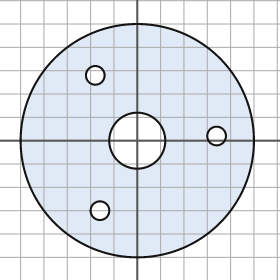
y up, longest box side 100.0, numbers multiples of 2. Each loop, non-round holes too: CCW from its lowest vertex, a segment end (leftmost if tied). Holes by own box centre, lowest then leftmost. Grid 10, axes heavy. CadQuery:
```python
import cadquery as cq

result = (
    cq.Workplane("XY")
    .moveTo(0.0, 0.0)
    .circle(50.0)
    .moveTo(-16.0, -30.0)
    .circle(4.0)
    .moveTo(0.0, 0.0)
    .circle(12.0)
    .moveTo(34.0, 2.0)
    .circle(4.0)
    .moveTo(-18.0, 28.0)
    .circle(4.0)
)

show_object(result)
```